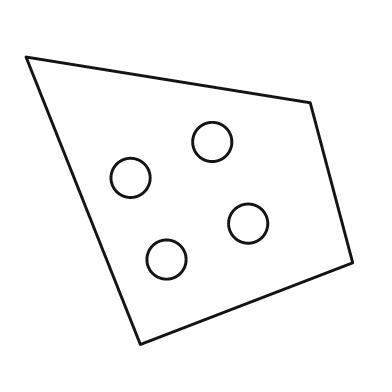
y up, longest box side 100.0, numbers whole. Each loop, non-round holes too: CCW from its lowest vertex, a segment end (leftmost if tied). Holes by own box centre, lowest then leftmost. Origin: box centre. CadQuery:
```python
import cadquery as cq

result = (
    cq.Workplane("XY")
    .moveTo(-15.0, -44.0)
    .lineTo(50.0, -19.0)
    .lineTo(37.0, 30.0)
    .lineTo(-50.0, 44.0)
    .close()
    .moveTo(-7.0, -18.0)
    .circle(6.0)
    .moveTo(18.0, -7.0)
    .circle(6.0)
    .moveTo(-18.0, 7.0)
    .circle(6.0)
    .moveTo(7.0, 18.0)
    .circle(6.0)
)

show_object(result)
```